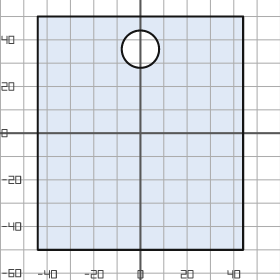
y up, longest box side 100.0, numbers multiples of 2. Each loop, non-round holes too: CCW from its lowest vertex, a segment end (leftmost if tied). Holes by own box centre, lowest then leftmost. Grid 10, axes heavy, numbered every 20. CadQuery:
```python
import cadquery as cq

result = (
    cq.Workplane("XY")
    .moveTo(-44.0, -50.0)
    .lineTo(44.0, -50.0)
    .lineTo(44.0, 50.0)
    .lineTo(-44.0, 50.0)
    .close()
    .moveTo(0.0, 36.0)
    .circle(8.0)
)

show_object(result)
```